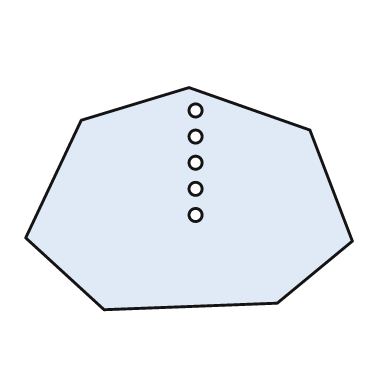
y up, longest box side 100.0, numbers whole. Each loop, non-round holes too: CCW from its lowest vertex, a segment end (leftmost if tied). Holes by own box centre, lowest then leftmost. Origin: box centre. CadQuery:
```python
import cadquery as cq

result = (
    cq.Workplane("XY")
    .moveTo(-26.0, -34.0)
    .lineTo(27.0, -32.0)
    .lineTo(50.0, -13.0)
    .lineTo(37.0, 21.0)
    .lineTo(0.0, 34.0)
    .lineTo(-33.0, 24.0)
    .lineTo(-50.0, -12.0)
    .close()
    .moveTo(2.0, -5.0)
    .circle(2.0)
    .moveTo(2.0, 3.0)
    .circle(2.0)
    .moveTo(2.0, 11.0)
    .circle(2.0)
    .moveTo(2.0, 19.0)
    .circle(2.0)
    .moveTo(2.0, 27.0)
    .circle(2.0)
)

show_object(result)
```